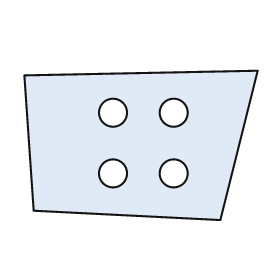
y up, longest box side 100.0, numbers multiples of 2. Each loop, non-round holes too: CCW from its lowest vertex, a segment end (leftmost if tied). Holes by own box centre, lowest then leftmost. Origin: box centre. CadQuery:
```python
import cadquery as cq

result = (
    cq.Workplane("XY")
    .moveTo(34.0, -32.0)
    .lineTo(50.0, 32.0)
    .lineTo(-50.0, 30.0)
    .lineTo(-46.0, -28.0)
    .close()
    .moveTo(-12.0, -12.0)
    .circle(6.0)
    .moveTo(14.0, -12.0)
    .circle(6.0)
    .moveTo(-12.0, 14.0)
    .circle(6.0)
    .moveTo(14.0, 14.0)
    .circle(6.0)
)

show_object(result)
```